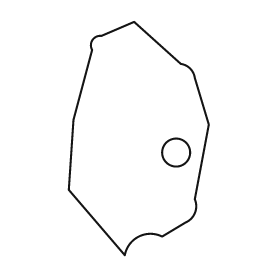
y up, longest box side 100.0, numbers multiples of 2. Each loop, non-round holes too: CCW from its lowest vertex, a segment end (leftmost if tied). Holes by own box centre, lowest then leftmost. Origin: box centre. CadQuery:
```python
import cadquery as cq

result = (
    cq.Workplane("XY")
    .moveTo(-6.0, -50.0)
    .threePointArc((0.0, -42.0), (10.0, -42.0))
    .lineTo(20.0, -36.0)
    .threePointArc((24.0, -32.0), (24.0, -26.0))
    .lineTo(30.0, 6.0)
    .lineTo(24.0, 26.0)
    .threePointArc((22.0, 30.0), (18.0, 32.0))
    .lineTo(-2.0, 50.0)
    .lineTo(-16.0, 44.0)
    .threePointArc((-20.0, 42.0), (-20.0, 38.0))
    .lineTo(-28.0, 8.0)
    .lineTo(-30.0, -22.0)
    .close()
    .moveTo(16.0, -6.0)
    .circle(6.0)
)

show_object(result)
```